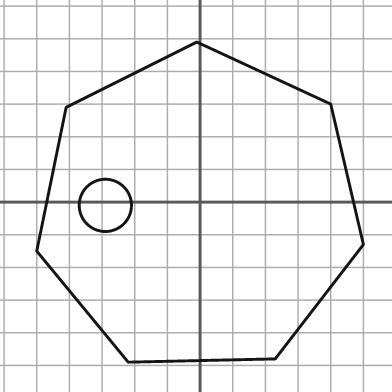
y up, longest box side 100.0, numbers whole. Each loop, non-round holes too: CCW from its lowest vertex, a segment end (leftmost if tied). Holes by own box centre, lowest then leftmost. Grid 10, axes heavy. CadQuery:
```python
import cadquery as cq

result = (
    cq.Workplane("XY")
    .moveTo(-22.0, -49.0)
    .lineTo(23.0, -48.0)
    .lineTo(50.0, -13.0)
    .lineTo(40.0, 30.0)
    .lineTo(-1.0, 49.0)
    .lineTo(-41.0, 29.0)
    .lineTo(-50.0, -15.0)
    .close()
    .moveTo(-29.0, -1.0)
    .circle(8.0)
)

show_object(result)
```